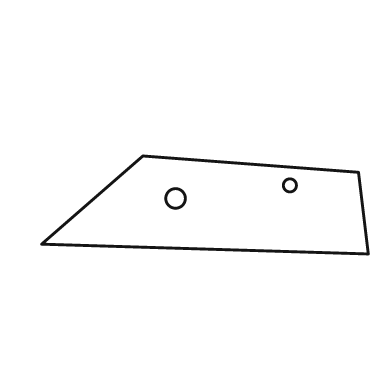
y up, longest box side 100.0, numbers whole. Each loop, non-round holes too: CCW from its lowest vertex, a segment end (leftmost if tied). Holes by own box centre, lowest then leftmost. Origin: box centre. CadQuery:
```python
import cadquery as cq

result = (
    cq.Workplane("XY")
    .moveTo(50.0, -15.0)
    .lineTo(47.0, 10.0)
    .lineTo(-19.0, 15.0)
    .lineTo(-50.0, -12.0)
    .close()
    .moveTo(-9.0, 2.0)
    .circle(3.0)
    .moveTo(26.0, 6.0)
    .circle(2.0)
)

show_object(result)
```